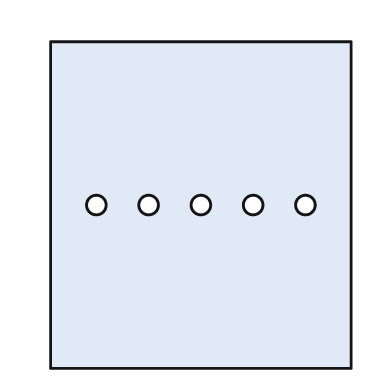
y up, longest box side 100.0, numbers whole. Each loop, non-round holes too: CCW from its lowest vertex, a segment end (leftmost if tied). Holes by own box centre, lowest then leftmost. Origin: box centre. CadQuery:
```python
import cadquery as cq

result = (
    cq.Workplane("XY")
    .moveTo(-46.0, -50.0)
    .lineTo(46.0, -50.0)
    .lineTo(46.0, 50.0)
    .lineTo(-46.0, 50.0)
    .close()
    .moveTo(-32.0, 0.0)
    .circle(3.0)
    .moveTo(-16.0, 0.0)
    .circle(3.0)
    .moveTo(0.0, 0.0)
    .circle(3.0)
    .moveTo(16.0, 0.0)
    .circle(3.0)
    .moveTo(32.0, 0.0)
    .circle(3.0)
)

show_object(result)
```